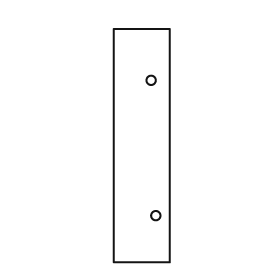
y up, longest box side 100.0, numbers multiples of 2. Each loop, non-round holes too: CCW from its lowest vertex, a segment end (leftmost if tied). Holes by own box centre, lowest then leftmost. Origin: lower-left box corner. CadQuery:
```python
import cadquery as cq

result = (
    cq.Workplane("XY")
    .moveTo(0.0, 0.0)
    .lineTo(24.0, 0.0)
    .lineTo(24.0, 100.0)
    .lineTo(0.0, 100.0)
    .close()
    .moveTo(18.0, 20.0)
    .circle(2.0)
    .moveTo(16.0, 78.0)
    .circle(2.0)
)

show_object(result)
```